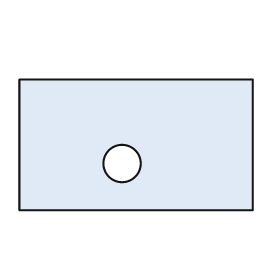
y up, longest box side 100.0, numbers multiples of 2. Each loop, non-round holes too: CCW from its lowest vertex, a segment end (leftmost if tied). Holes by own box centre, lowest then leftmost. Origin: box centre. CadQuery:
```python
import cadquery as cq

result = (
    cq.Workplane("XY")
    .moveTo(-50.0, -28.0)
    .lineTo(50.0, -28.0)
    .lineTo(50.0, 28.0)
    .lineTo(-50.0, 28.0)
    .close()
    .moveTo(-6.0, -8.0)
    .circle(8.0)
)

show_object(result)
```